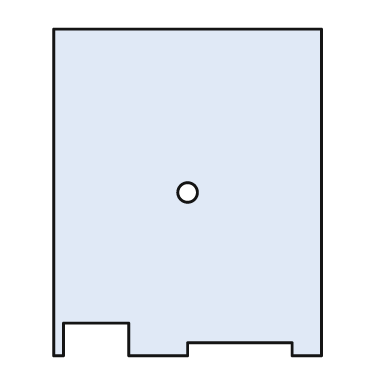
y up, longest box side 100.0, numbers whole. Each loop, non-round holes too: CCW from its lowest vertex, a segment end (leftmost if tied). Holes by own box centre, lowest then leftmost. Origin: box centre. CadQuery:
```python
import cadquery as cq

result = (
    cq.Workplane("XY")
    .moveTo(-41.0, -50.0)
    .lineTo(-38.0, -50.0)
    .lineTo(-38.0, -40.0)
    .lineTo(-18.0, -40.0)
    .lineTo(-18.0, -50.0)
    .lineTo(0.0, -50.0)
    .lineTo(0.0, -46.0)
    .lineTo(32.0, -46.0)
    .lineTo(32.0, -50.0)
    .lineTo(41.0, -50.0)
    .lineTo(41.0, 50.0)
    .lineTo(-41.0, 50.0)
    .close()
    .moveTo(0.0, 0.0)
    .circle(3.0)
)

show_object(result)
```